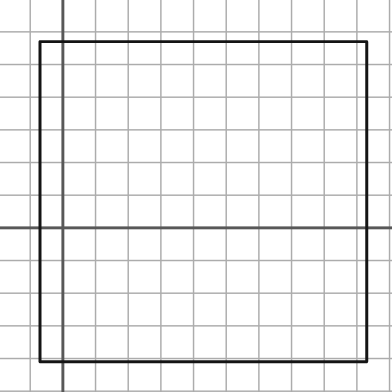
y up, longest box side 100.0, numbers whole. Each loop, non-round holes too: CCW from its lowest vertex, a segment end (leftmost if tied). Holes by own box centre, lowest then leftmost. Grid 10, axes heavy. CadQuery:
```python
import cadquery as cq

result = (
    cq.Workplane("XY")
    .moveTo(-7.0, -41.0)
    .lineTo(93.0, -41.0)
    .lineTo(93.0, 57.0)
    .lineTo(-7.0, 57.0)
    .close()
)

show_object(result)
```